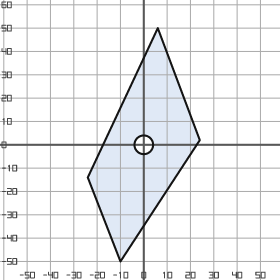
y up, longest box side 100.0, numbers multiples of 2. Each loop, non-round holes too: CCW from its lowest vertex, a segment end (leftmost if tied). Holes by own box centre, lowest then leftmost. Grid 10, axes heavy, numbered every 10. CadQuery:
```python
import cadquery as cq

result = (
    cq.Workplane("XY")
    .moveTo(-10.0, -50.0)
    .lineTo(24.0, 2.0)
    .lineTo(6.0, 50.0)
    .lineTo(-24.0, -14.0)
    .close()
    .moveTo(0.0, 0.0)
    .circle(4.0)
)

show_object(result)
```